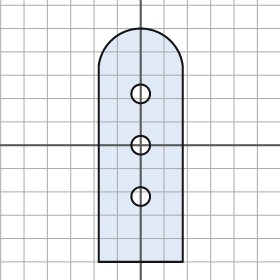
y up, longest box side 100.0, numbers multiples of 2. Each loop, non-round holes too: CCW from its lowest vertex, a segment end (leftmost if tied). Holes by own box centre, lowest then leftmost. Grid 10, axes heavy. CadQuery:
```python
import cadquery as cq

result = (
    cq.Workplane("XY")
    .moveTo(-18.0, -50.0)
    .lineTo(18.0, -50.0)
    .lineTo(18.0, 34.0)
    .threePointArc((0.0, 50.0), (-18.0, 34.0))
    .close()
    .moveTo(0.0, -22.0)
    .circle(4.0)
    .moveTo(0.0, 0.0)
    .circle(4.0)
    .moveTo(0.0, 22.0)
    .circle(4.0)
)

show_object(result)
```